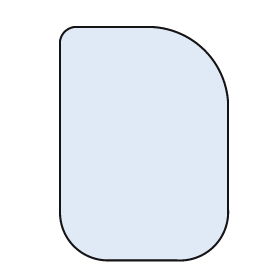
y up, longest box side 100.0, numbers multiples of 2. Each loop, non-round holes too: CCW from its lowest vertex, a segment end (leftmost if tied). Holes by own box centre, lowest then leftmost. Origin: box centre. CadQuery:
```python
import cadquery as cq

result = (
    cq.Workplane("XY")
    .moveTo(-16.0, -50.0)
    .lineTo(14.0, -50.0)
    .threePointArc((30.0, -44.0), (36.0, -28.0))
    .lineTo(36.0, 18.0)
    .threePointArc((26.0, 40.0), (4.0, 50.0))
    .lineTo(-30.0, 50.0)
    .threePointArc((-34.0, 48.0), (-36.0, 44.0))
    .lineTo(-36.0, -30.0)
    .threePointArc((-30.0, -44.0), (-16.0, -50.0))
    .close()
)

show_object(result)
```